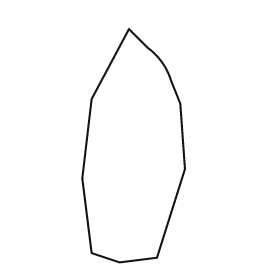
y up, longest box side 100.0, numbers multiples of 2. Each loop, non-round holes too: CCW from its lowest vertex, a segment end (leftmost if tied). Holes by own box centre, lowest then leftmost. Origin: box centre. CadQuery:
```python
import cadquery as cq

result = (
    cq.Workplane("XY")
    .moveTo(-6.0, -50.0)
    .lineTo(10.0, -48.0)
    .lineTo(22.0, -10.0)
    .lineTo(20.0, 18.0)
    .lineTo(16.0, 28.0)
    .threePointArc((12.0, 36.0), (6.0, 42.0))
    .lineTo(-2.0, 50.0)
    .lineTo(-18.0, 20.0)
    .lineTo(-22.0, -14.0)
    .lineTo(-18.0, -46.0)
    .close()
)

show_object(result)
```